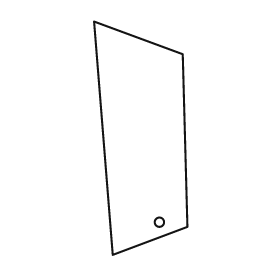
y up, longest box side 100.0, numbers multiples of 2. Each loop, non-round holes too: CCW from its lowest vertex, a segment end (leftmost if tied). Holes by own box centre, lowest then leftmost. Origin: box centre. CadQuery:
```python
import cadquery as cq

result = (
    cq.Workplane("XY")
    .moveTo(-12.0, -50.0)
    .lineTo(20.0, -38.0)
    .lineTo(18.0, 36.0)
    .lineTo(-20.0, 50.0)
    .close()
    .moveTo(8.0, -36.0)
    .circle(2.0)
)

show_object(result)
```